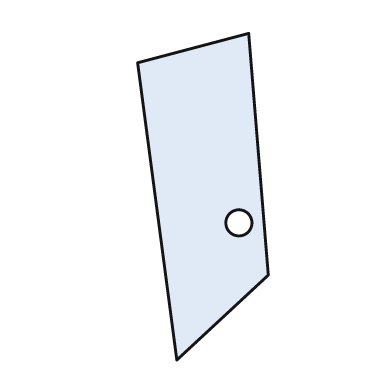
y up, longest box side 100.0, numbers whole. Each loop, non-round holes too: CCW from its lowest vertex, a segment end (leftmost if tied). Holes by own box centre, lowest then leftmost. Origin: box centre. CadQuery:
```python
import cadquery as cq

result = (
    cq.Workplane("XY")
    .moveTo(-8.0, -50.0)
    .lineTo(20.0, -24.0)
    .lineTo(14.0, 50.0)
    .lineTo(-20.0, 41.0)
    .close()
    .moveTo(11.0, -8.0)
    .circle(4.0)
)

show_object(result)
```